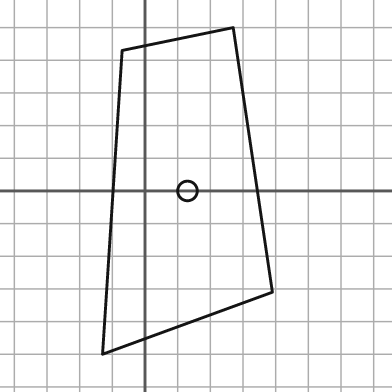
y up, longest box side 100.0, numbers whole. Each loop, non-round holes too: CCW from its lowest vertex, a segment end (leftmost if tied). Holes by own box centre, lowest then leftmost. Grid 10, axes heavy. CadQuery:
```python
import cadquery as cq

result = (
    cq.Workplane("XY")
    .moveTo(-13.0, -50.0)
    .lineTo(39.0, -31.0)
    .lineTo(27.0, 50.0)
    .lineTo(-7.0, 43.0)
    .close()
    .moveTo(13.0, 0.0)
    .circle(3.0)
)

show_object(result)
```